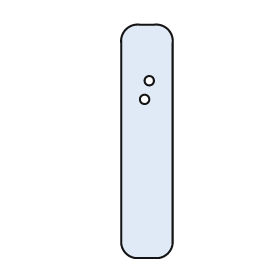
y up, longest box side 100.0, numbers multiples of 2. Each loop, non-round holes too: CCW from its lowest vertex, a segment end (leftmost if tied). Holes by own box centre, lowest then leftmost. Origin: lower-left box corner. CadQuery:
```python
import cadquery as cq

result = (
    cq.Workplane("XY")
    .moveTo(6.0, 0.0)
    .lineTo(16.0, 0.0)
    .threePointArc((20.0, 2.0), (22.0, 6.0))
    .lineTo(22.0, 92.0)
    .threePointArc((20.0, 98.0), (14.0, 100.0))
    .lineTo(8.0, 100.0)
    .threePointArc((2.0, 98.0), (0.0, 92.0))
    .lineTo(0.0, 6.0)
    .threePointArc((2.0, 2.0), (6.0, 0.0))
    .close()
    .moveTo(10.0, 68.0)
    .circle(2.0)
    .moveTo(12.0, 76.0)
    .circle(2.0)
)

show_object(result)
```